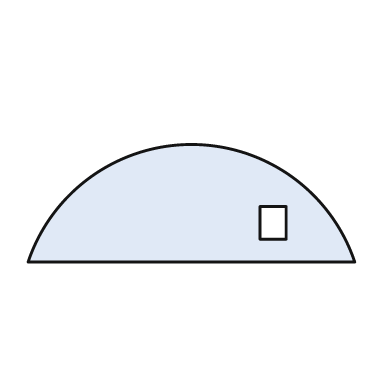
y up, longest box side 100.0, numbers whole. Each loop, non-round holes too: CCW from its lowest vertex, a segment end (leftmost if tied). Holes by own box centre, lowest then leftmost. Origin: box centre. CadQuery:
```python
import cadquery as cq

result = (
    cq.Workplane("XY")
    .moveTo(-50.0, -18.0)
    .lineTo(50.0, -18.0)
    .threePointArc((0.0, 18.0), (-50.0, -18.0))
    .close()
    .moveTo(21.0, -11.0)
    .lineTo(29.0, -11.0)
    .lineTo(29.0, -1.0)
    .lineTo(21.0, -1.0)
    .close()
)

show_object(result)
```